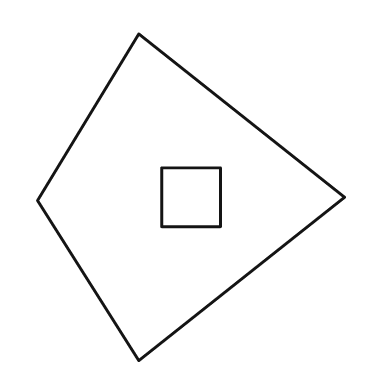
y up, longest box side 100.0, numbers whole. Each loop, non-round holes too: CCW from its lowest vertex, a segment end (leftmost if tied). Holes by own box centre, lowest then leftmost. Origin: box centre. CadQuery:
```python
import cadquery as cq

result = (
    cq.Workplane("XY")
    .moveTo(-16.0, -50.0)
    .lineTo(47.0, 0.0)
    .lineTo(-16.0, 50.0)
    .lineTo(-47.0, -1.0)
    .close()
    .moveTo(-9.0, -9.0)
    .lineTo(9.0, -9.0)
    .lineTo(9.0, 9.0)
    .lineTo(-9.0, 9.0)
    .close()
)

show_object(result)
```